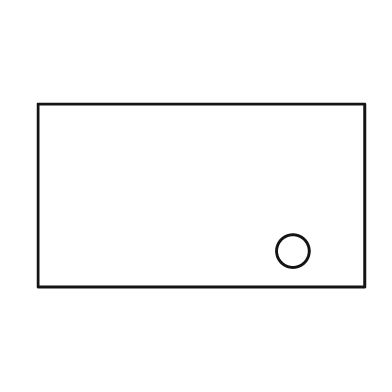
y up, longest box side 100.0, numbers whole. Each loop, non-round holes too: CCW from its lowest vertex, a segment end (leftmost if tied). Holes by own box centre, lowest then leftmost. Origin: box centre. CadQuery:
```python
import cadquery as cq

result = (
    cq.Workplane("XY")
    .moveTo(-50.0, -28.0)
    .lineTo(50.0, -28.0)
    .lineTo(50.0, 28.0)
    .lineTo(-50.0, 28.0)
    .close()
    .moveTo(28.0, -17.0)
    .circle(5.0)
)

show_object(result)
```